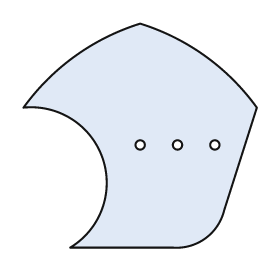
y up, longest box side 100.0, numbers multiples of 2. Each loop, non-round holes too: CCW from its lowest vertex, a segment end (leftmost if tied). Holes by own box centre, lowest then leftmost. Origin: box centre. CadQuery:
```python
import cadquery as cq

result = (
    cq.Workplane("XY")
    .moveTo(-30.0, -48.0)
    .lineTo(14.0, -48.0)
    .threePointArc((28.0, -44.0), (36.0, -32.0))
    .lineTo(50.0, 12.0)
    .threePointArc((28.0, 34.0), (0.0, 48.0))
    .threePointArc((-28.0, 34.0), (-50.0, 12.0))
    .threePointArc((-16.0, -10.0), (-30.0, -48.0))
    .close()
    .moveTo(0.0, -4.0)
    .circle(2.0)
    .moveTo(16.0, -4.0)
    .circle(2.0)
    .moveTo(32.0, -4.0)
    .circle(2.0)
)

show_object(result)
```